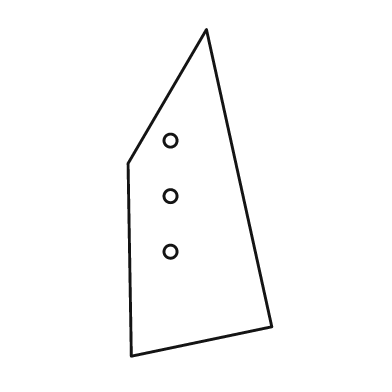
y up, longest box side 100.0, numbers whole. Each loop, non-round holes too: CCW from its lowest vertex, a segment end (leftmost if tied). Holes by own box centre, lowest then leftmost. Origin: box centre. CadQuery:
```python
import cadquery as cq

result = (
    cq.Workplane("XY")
    .moveTo(-21.0, -50.0)
    .lineTo(22.0, -41.0)
    .lineTo(2.0, 50.0)
    .lineTo(-22.0, 9.0)
    .close()
    .moveTo(-9.0, -18.0)
    .circle(2.0)
    .moveTo(-9.0, -1.0)
    .circle(2.0)
    .moveTo(-9.0, 16.0)
    .circle(2.0)
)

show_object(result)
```